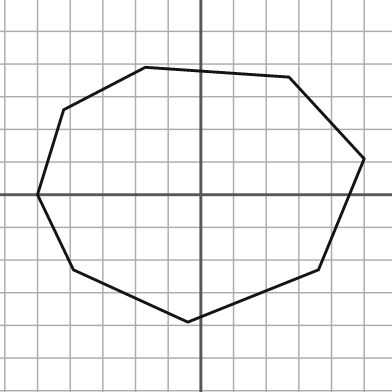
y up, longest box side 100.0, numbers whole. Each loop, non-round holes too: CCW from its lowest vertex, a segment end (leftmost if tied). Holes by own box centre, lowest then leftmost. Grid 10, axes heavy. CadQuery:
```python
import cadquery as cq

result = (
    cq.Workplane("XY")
    .moveTo(-4.0, -39.0)
    .lineTo(36.0, -23.0)
    .lineTo(50.0, 11.0)
    .lineTo(27.0, 36.0)
    .lineTo(-17.0, 39.0)
    .lineTo(-42.0, 26.0)
    .lineTo(-50.0, 0.0)
    .lineTo(-39.0, -23.0)
    .close()
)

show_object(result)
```